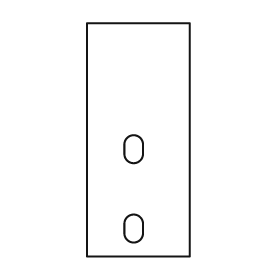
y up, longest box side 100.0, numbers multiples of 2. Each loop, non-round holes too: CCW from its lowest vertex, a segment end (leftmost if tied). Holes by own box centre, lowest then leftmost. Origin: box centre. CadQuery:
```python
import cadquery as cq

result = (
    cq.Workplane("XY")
    .moveTo(-22.0, -50.0)
    .lineTo(22.0, -50.0)
    .lineTo(22.0, 50.0)
    .lineTo(-22.0, 50.0)
    .close()
    .moveTo(-6.0, -40.0)
    .threePointArc((-2.0, -44.0), (2.0, -40.0))
    .lineTo(2.0, -36.0)
    .threePointArc((-2.0, -32.0), (-6.0, -36.0))
    .close()
    .moveTo(-6.0, -6.0)
    .threePointArc((-2.0, -10.0), (2.0, -6.0))
    .lineTo(2.0, -2.0)
    .threePointArc((-2.0, 2.0), (-6.0, -2.0))
    .close()
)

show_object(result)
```